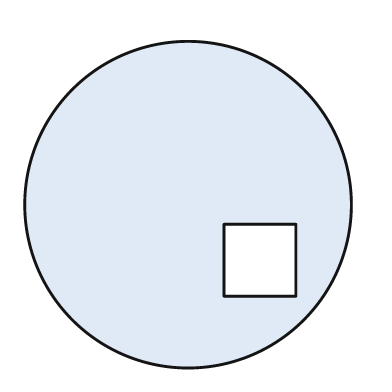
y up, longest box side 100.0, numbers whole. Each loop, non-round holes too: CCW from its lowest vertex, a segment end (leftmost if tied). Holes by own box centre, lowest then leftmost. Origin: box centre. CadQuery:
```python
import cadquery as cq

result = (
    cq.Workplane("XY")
    .moveTo(0.0, 0.0)
    .circle(50.0)
    .moveTo(11.0, -28.0)
    .lineTo(33.0, -28.0)
    .lineTo(33.0, -6.0)
    .lineTo(11.0, -6.0)
    .close()
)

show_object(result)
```